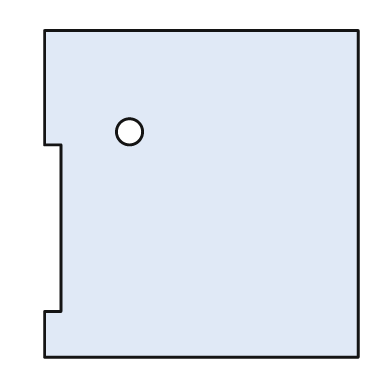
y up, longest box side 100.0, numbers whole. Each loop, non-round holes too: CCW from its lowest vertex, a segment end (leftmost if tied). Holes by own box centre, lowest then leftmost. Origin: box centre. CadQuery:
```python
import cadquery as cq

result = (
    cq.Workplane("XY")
    .moveTo(-48.0, -50.0)
    .lineTo(48.0, -50.0)
    .lineTo(48.0, 50.0)
    .lineTo(-48.0, 50.0)
    .lineTo(-48.0, 15.0)
    .lineTo(-43.0, 15.0)
    .lineTo(-43.0, -36.0)
    .lineTo(-48.0, -36.0)
    .close()
    .moveTo(-22.0, 19.0)
    .circle(4.0)
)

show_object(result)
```